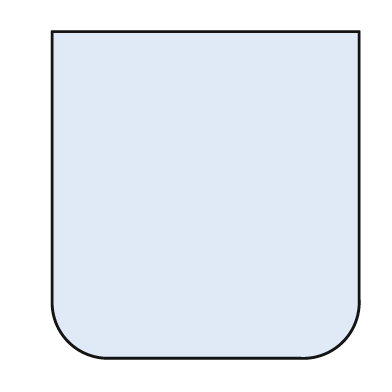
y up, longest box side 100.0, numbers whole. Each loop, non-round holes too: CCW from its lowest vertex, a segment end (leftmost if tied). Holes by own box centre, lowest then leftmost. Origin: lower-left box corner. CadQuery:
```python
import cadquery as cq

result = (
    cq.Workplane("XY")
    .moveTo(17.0, 0.0)
    .lineTo(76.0, 0.0)
    .threePointArc((89.0, 5.0), (94.0, 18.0))
    .lineTo(94.0, 100.0)
    .lineTo(0.0, 100.0)
    .lineTo(0.0, 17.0)
    .threePointArc((5.0, 5.0), (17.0, 0.0))
    .close()
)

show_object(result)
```